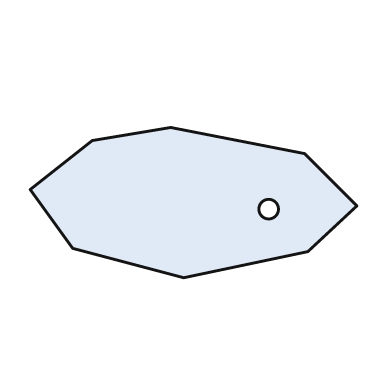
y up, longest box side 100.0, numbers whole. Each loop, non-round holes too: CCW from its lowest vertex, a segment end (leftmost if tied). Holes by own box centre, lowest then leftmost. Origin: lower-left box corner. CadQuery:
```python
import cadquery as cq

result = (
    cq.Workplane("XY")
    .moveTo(47.0, 0.0)
    .lineTo(85.0, 8.0)
    .lineTo(100.0, 22.0)
    .lineTo(84.0, 38.0)
    .lineTo(43.0, 46.0)
    .lineTo(19.0, 42.0)
    .lineTo(0.0, 27.0)
    .lineTo(13.0, 9.0)
    .close()
    .moveTo(73.0, 21.0)
    .circle(3.0)
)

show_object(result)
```